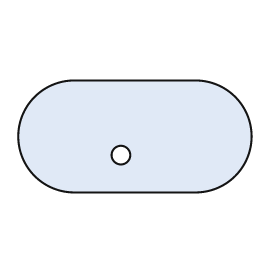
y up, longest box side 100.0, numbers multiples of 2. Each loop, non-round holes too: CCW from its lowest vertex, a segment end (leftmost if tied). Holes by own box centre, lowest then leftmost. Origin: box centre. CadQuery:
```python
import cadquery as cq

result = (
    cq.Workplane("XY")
    .moveTo(-26.0, -24.0)
    .lineTo(26.0, -24.0)
    .threePointArc((50.0, 0.0), (26.0, 24.0))
    .lineTo(-26.0, 24.0)
    .threePointArc((-50.0, 0.0), (-26.0, -24.0))
    .close()
    .moveTo(-6.0, -8.0)
    .circle(4.0)
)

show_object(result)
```